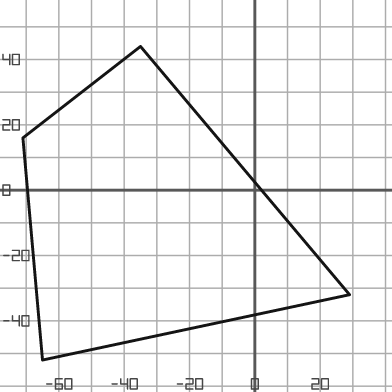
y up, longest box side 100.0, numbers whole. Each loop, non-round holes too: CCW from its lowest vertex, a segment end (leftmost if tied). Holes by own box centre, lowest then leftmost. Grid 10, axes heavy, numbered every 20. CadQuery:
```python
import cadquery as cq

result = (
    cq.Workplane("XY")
    .moveTo(-65.0, -52.0)
    .lineTo(29.0, -32.0)
    .lineTo(-35.0, 44.0)
    .lineTo(-71.0, 16.0)
    .close()
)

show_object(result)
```